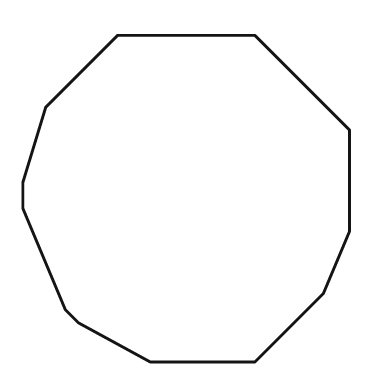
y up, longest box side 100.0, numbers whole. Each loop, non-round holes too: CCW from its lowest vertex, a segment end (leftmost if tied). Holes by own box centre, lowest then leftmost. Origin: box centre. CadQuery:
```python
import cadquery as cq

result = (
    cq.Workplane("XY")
    .moveTo(-11.0, -50.0)
    .lineTo(21.0, -50.0)
    .lineTo(42.0, -29.0)
    .lineTo(50.0, -10.0)
    .lineTo(50.0, 21.0)
    .lineTo(21.0, 50.0)
    .lineTo(-21.0, 50.0)
    .lineTo(-43.0, 28.0)
    .lineTo(-50.0, 5.0)
    .lineTo(-50.0, -3.0)
    .lineTo(-37.0, -34.0)
    .lineTo(-33.0, -38.0)
    .close()
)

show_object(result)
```